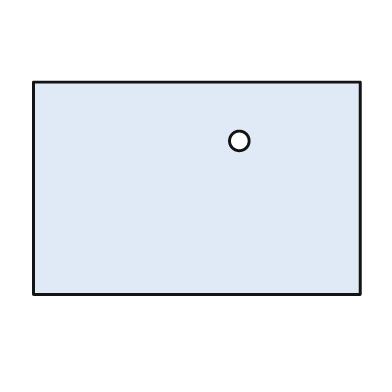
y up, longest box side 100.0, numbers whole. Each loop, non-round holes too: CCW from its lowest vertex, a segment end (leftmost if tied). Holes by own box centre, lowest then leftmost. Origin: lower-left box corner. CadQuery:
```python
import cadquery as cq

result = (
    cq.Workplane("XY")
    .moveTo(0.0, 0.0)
    .lineTo(100.0, 0.0)
    .lineTo(100.0, 65.0)
    .lineTo(0.0, 65.0)
    .close()
    .moveTo(63.0, 47.0)
    .circle(3.0)
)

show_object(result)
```